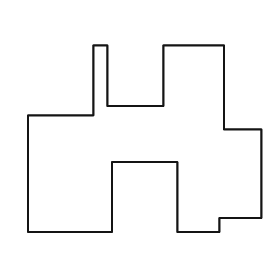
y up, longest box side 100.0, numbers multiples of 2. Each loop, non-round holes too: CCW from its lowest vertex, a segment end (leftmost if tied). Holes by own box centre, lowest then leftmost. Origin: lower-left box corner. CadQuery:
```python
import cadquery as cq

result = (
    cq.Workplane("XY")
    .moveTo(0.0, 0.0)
    .lineTo(36.0, 0.0)
    .lineTo(36.0, 30.0)
    .lineTo(64.0, 30.0)
    .lineTo(64.0, 0.0)
    .lineTo(82.0, 0.0)
    .lineTo(82.0, 6.0)
    .lineTo(100.0, 6.0)
    .lineTo(100.0, 44.0)
    .lineTo(84.0, 44.0)
    .lineTo(84.0, 80.0)
    .lineTo(58.0, 80.0)
    .lineTo(58.0, 54.0)
    .lineTo(34.0, 54.0)
    .lineTo(34.0, 80.0)
    .lineTo(28.0, 80.0)
    .lineTo(28.0, 50.0)
    .lineTo(0.0, 50.0)
    .close()
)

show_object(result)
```